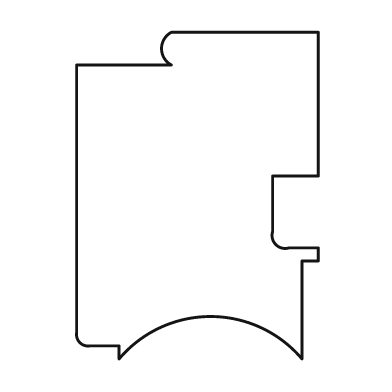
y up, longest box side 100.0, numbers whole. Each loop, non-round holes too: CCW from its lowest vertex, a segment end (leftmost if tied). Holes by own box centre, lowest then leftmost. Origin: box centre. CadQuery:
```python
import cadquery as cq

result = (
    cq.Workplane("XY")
    .moveTo(-24.0, -50.0)
    .threePointArc((4.0, -37.0), (32.0, -50.0))
    .lineTo(32.0, -20.0)
    .lineTo(37.0, -20.0)
    .lineTo(37.0, -16.0)
    .lineTo(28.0, -16.0)
    .threePointArc((24.0, -15.0), (23.0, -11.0))
    .lineTo(23.0, 6.0)
    .lineTo(37.0, 6.0)
    .lineTo(37.0, 50.0)
    .lineTo(-8.0, 50.0)
    .threePointArc((-11.0, 45.0), (-8.0, 40.0))
    .lineTo(-37.0, 40.0)
    .lineTo(-37.0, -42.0)
    .threePointArc((-36.0, -45.0), (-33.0, -46.0))
    .lineTo(-24.0, -46.0)
    .close()
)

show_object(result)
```